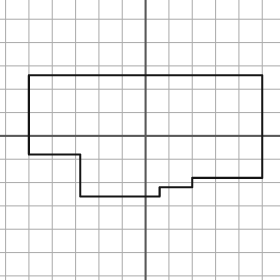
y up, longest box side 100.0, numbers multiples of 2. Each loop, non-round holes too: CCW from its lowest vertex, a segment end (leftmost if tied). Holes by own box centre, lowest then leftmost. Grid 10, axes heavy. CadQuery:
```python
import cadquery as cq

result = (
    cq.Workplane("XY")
    .moveTo(-28.0, -26.0)
    .lineTo(6.0, -26.0)
    .lineTo(6.0, -22.0)
    .lineTo(20.0, -22.0)
    .lineTo(20.0, -18.0)
    .lineTo(50.0, -18.0)
    .lineTo(50.0, 26.0)
    .lineTo(-50.0, 26.0)
    .lineTo(-50.0, -8.0)
    .lineTo(-28.0, -8.0)
    .close()
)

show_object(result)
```